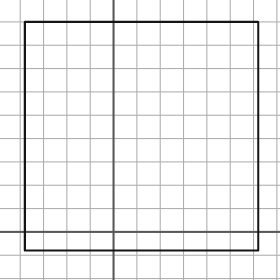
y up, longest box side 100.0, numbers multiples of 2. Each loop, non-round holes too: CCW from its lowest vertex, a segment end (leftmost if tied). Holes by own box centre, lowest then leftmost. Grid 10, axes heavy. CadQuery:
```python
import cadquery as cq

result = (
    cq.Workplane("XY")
    .moveTo(-38.0, -8.0)
    .lineTo(62.0, -8.0)
    .lineTo(62.0, 90.0)
    .lineTo(-38.0, 90.0)
    .close()
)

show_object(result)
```